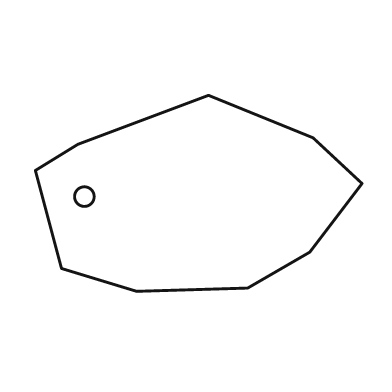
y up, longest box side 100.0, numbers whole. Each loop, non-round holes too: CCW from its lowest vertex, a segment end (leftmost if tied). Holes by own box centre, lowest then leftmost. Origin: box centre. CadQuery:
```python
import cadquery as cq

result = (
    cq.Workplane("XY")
    .moveTo(-19.0, -30.0)
    .lineTo(15.0, -29.0)
    .lineTo(34.0, -18.0)
    .lineTo(50.0, 3.0)
    .lineTo(35.0, 17.0)
    .lineTo(3.0, 30.0)
    .lineTo(-37.0, 15.0)
    .lineTo(-50.0, 7.0)
    .lineTo(-42.0, -23.0)
    .close()
    .moveTo(-35.0, -1.0)
    .circle(3.0)
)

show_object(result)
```